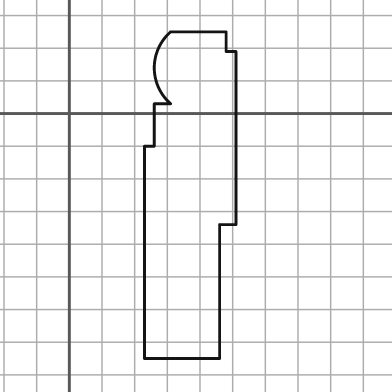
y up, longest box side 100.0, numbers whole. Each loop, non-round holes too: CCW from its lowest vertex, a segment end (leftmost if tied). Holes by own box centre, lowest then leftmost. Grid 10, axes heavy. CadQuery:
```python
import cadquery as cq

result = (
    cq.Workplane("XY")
    .moveTo(23.0, -75.0)
    .lineTo(46.0, -75.0)
    .lineTo(46.0, -34.0)
    .lineTo(51.0, -34.0)
    .lineTo(51.0, 19.0)
    .lineTo(48.0, 19.0)
    .lineTo(48.0, 25.0)
    .lineTo(31.0, 25.0)
    .threePointArc((26.0, 14.0), (31.0, 3.0))
    .lineTo(26.0, 3.0)
    .lineTo(26.0, -10.0)
    .lineTo(23.0, -10.0)
    .close()
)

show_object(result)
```